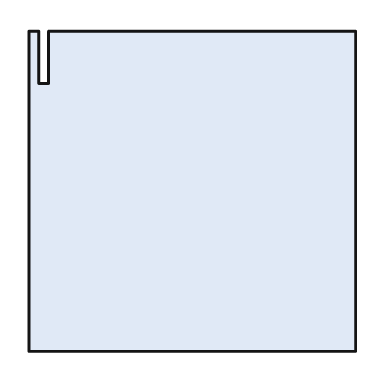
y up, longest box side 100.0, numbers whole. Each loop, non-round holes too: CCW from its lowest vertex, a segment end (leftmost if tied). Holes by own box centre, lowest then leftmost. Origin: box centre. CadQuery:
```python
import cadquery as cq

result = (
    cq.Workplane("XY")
    .moveTo(-50.0, -49.0)
    .lineTo(50.0, -49.0)
    .lineTo(50.0, 49.0)
    .lineTo(-44.0, 49.0)
    .lineTo(-44.0, 33.0)
    .lineTo(-47.0, 33.0)
    .lineTo(-47.0, 49.0)
    .lineTo(-50.0, 49.0)
    .close()
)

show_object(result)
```